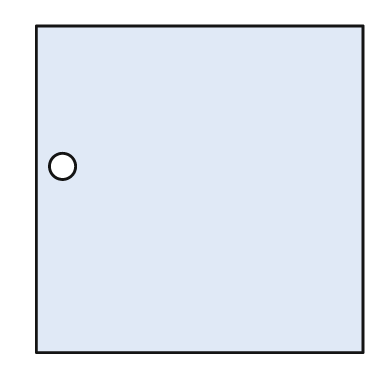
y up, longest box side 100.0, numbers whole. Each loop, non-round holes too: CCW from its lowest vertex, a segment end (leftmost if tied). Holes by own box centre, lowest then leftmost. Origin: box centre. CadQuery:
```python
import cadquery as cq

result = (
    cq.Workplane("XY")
    .moveTo(-50.0, -50.0)
    .lineTo(50.0, -50.0)
    .lineTo(50.0, 50.0)
    .lineTo(-50.0, 50.0)
    .close()
    .moveTo(-42.0, 7.0)
    .circle(4.0)
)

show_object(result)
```